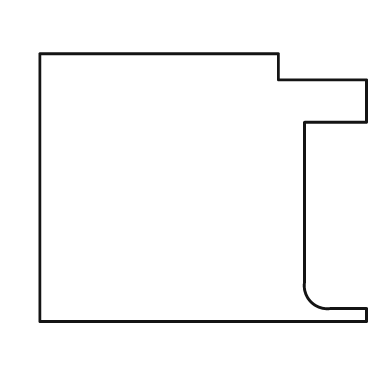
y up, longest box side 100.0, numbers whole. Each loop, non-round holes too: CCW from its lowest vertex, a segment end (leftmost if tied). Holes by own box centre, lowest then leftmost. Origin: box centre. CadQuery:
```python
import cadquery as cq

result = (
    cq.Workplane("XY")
    .moveTo(-50.0, -41.0)
    .lineTo(50.0, -41.0)
    .lineTo(50.0, -37.0)
    .lineTo(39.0, -37.0)
    .threePointArc((33.0, -35.0), (31.0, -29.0))
    .lineTo(31.0, 20.0)
    .lineTo(50.0, 20.0)
    .lineTo(50.0, 33.0)
    .lineTo(23.0, 33.0)
    .lineTo(23.0, 41.0)
    .lineTo(-50.0, 41.0)
    .close()
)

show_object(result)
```